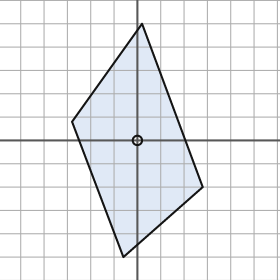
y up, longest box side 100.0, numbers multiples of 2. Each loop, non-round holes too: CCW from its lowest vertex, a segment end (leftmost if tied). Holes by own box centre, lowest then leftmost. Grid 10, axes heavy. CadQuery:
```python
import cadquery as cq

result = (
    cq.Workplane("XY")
    .moveTo(-6.0, -50.0)
    .lineTo(28.0, -20.0)
    .lineTo(2.0, 50.0)
    .lineTo(-28.0, 8.0)
    .close()
    .moveTo(0.0, 0.0)
    .circle(2.0)
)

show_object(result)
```